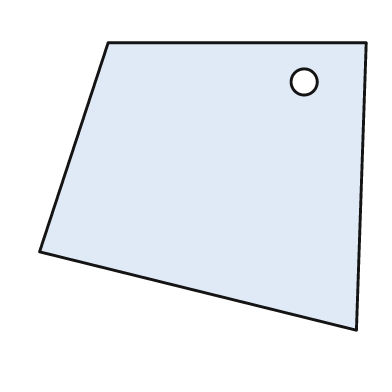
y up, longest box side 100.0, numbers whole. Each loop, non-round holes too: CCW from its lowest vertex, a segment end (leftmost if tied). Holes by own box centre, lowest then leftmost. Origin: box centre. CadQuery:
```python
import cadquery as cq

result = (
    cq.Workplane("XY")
    .moveTo(47.0, -44.0)
    .lineTo(50.0, 44.0)
    .lineTo(-29.0, 44.0)
    .lineTo(-50.0, -20.0)
    .close()
    .moveTo(31.0, 32.0)
    .circle(4.0)
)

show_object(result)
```